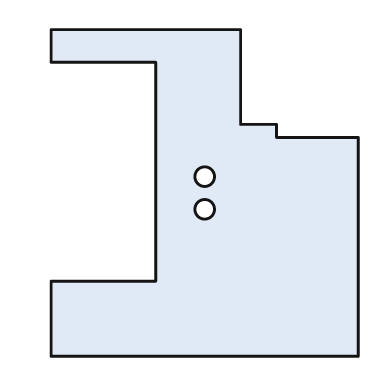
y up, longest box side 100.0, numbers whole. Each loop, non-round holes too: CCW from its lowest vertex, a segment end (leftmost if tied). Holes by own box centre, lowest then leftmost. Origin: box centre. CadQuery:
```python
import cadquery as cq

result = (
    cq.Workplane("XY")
    .moveTo(-47.0, -50.0)
    .lineTo(47.0, -50.0)
    .lineTo(47.0, 17.0)
    .lineTo(22.0, 17.0)
    .lineTo(22.0, 21.0)
    .lineTo(11.0, 21.0)
    .lineTo(11.0, 50.0)
    .lineTo(-47.0, 50.0)
    .lineTo(-47.0, 40.0)
    .lineTo(-15.0, 40.0)
    .lineTo(-15.0, -27.0)
    .lineTo(-47.0, -27.0)
    .close()
    .moveTo(0.0, -5.0)
    .circle(3.0)
    .moveTo(0.0, 5.0)
    .circle(3.0)
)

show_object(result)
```